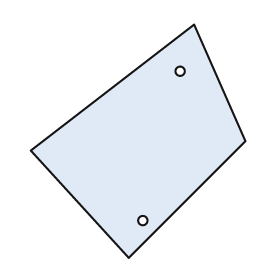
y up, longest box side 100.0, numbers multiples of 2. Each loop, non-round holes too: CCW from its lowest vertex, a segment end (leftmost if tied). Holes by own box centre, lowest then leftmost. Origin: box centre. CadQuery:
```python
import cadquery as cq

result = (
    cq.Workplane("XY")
    .moveTo(-4.0, -50.0)
    .lineTo(46.0, 0.0)
    .lineTo(24.0, 50.0)
    .lineTo(-46.0, -4.0)
    .close()
    .moveTo(2.0, -34.0)
    .circle(2.0)
    .moveTo(18.0, 30.0)
    .circle(2.0)
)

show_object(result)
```